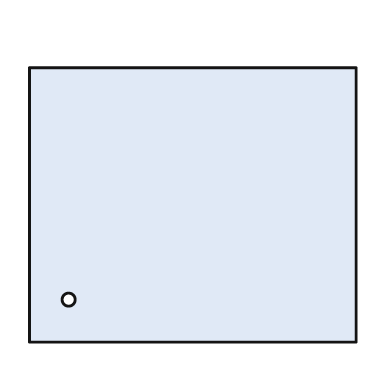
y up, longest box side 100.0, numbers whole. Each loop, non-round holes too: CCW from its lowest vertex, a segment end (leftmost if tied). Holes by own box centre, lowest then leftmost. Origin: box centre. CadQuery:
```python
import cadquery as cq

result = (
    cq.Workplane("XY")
    .moveTo(-50.0, -42.0)
    .lineTo(50.0, -42.0)
    .lineTo(50.0, 42.0)
    .lineTo(-50.0, 42.0)
    .close()
    .moveTo(-38.0, -29.0)
    .circle(2.0)
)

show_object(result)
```